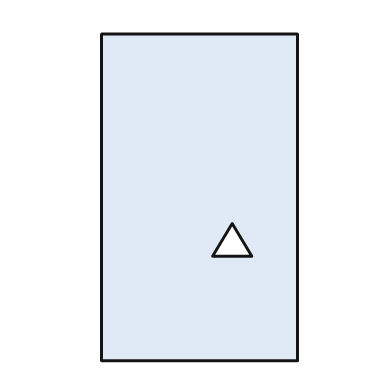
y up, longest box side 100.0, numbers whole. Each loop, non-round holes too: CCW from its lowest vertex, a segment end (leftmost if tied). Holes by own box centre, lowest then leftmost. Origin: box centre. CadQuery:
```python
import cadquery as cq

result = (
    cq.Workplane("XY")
    .moveTo(-30.0, -50.0)
    .lineTo(30.0, -50.0)
    .lineTo(30.0, 50.0)
    .lineTo(-30.0, 50.0)
    .close()
    .moveTo(4.0, -18.0)
    .lineTo(16.0, -18.0)
    .lineTo(10.0, -8.0)
    .close()
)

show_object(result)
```